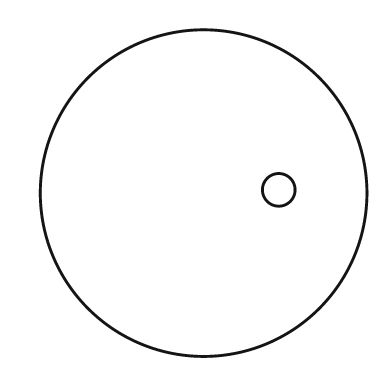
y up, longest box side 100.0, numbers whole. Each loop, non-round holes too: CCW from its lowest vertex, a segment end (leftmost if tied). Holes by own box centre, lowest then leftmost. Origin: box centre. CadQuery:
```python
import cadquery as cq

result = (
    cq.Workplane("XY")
    .moveTo(0.0, 0.0)
    .circle(50.0)
    .moveTo(23.0, 1.0)
    .circle(5.0)
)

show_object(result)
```